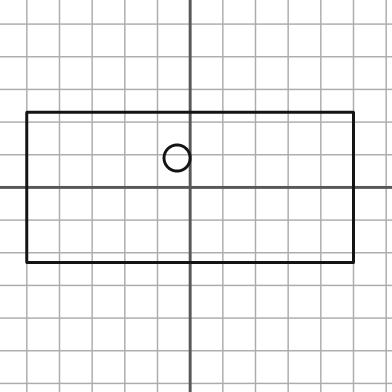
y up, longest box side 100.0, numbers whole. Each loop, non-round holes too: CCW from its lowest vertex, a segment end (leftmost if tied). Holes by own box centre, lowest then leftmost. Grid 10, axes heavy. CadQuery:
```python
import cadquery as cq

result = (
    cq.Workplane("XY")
    .moveTo(-50.0, -23.0)
    .lineTo(50.0, -23.0)
    .lineTo(50.0, 23.0)
    .lineTo(-50.0, 23.0)
    .close()
    .moveTo(-4.0, 9.0)
    .circle(4.0)
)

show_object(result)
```